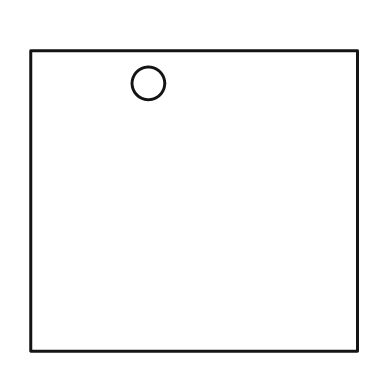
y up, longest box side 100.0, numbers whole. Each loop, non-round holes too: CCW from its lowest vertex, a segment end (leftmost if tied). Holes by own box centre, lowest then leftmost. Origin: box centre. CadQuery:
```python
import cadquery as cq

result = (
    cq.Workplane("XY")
    .moveTo(-50.0, -46.0)
    .lineTo(50.0, -46.0)
    .lineTo(50.0, 46.0)
    .lineTo(-50.0, 46.0)
    .close()
    .moveTo(-14.0, 36.0)
    .circle(5.0)
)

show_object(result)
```